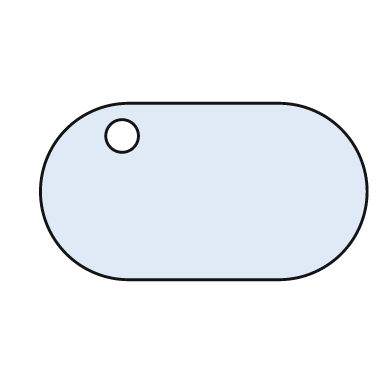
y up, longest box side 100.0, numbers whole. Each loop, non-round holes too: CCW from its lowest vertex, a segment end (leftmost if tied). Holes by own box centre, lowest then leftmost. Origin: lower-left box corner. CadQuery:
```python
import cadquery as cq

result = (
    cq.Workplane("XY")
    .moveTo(27.0, 0.0)
    .lineTo(73.0, 0.0)
    .threePointArc((100.0, 27.0), (73.0, 54.0))
    .lineTo(27.0, 54.0)
    .threePointArc((0.0, 27.0), (27.0, 0.0))
    .close()
    .moveTo(25.0, 44.0)
    .circle(5.0)
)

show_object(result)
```